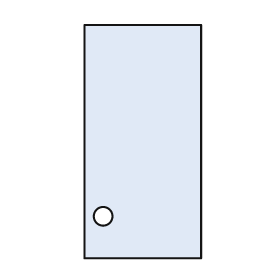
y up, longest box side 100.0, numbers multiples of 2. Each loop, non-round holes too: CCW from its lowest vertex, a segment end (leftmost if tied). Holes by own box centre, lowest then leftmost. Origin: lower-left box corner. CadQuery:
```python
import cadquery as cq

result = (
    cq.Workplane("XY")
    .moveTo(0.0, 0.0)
    .lineTo(50.0, 0.0)
    .lineTo(50.0, 100.0)
    .lineTo(0.0, 100.0)
    .close()
    .moveTo(8.0, 18.0)
    .circle(4.0)
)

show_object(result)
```